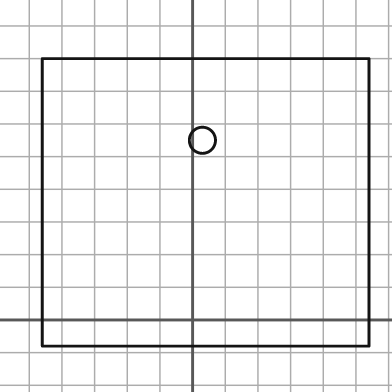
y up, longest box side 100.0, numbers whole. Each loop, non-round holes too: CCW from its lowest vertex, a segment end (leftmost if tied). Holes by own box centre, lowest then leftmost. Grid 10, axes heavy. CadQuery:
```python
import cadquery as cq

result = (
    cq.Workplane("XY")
    .moveTo(-46.0, -8.0)
    .lineTo(54.0, -8.0)
    .lineTo(54.0, 80.0)
    .lineTo(-46.0, 80.0)
    .close()
    .moveTo(3.0, 55.0)
    .circle(4.0)
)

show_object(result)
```